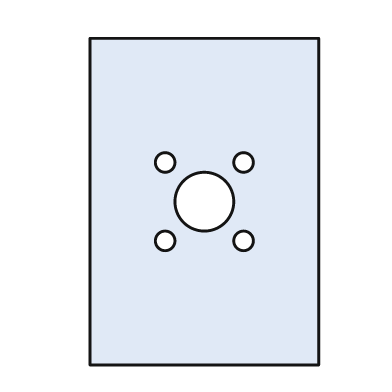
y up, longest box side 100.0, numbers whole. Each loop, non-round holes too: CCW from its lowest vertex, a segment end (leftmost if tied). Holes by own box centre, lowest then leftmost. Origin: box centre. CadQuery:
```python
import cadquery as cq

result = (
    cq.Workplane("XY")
    .moveTo(-35.0, -50.0)
    .lineTo(35.0, -50.0)
    .lineTo(35.0, 50.0)
    .lineTo(-35.0, 50.0)
    .close()
    .moveTo(-12.0, -12.0)
    .circle(3.0)
    .moveTo(12.0, -12.0)
    .circle(3.0)
    .moveTo(0.0, 0.0)
    .circle(9.0)
    .moveTo(-12.0, 12.0)
    .circle(3.0)
    .moveTo(12.0, 12.0)
    .circle(3.0)
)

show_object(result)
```